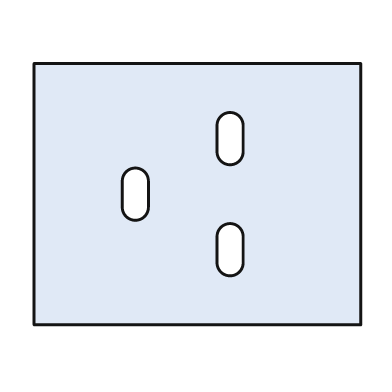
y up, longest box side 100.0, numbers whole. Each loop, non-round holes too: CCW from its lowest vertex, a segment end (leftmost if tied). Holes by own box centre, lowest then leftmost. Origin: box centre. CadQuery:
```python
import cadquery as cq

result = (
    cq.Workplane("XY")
    .moveTo(-50.0, -40.0)
    .lineTo(50.0, -40.0)
    .lineTo(50.0, 40.0)
    .lineTo(-50.0, 40.0)
    .close()
    .moveTo(6.0, -21.0)
    .threePointArc((10.0, -25.0), (14.0, -21.0))
    .lineTo(14.0, -13.0)
    .threePointArc((10.0, -9.0), (6.0, -13.0))
    .close()
    .moveTo(-23.0, -4.0)
    .threePointArc((-19.0, -8.0), (-15.0, -4.0))
    .lineTo(-15.0, 4.0)
    .threePointArc((-19.0, 8.0), (-23.0, 4.0))
    .close()
    .moveTo(6.0, 13.0)
    .threePointArc((10.0, 9.0), (14.0, 13.0))
    .lineTo(14.0, 21.0)
    .threePointArc((10.0, 25.0), (6.0, 21.0))
    .close()
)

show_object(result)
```